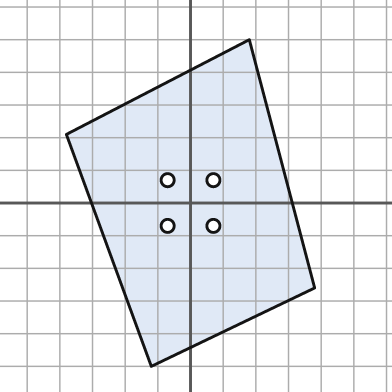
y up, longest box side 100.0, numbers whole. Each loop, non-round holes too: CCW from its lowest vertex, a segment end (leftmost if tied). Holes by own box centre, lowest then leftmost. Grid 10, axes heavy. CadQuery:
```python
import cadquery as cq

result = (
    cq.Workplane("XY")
    .moveTo(-12.0, -50.0)
    .lineTo(38.0, -26.0)
    .lineTo(18.0, 50.0)
    .lineTo(-38.0, 21.0)
    .close()
    .moveTo(-7.0, -7.0)
    .circle(2.0)
    .moveTo(7.0, -7.0)
    .circle(2.0)
    .moveTo(-7.0, 7.0)
    .circle(2.0)
    .moveTo(7.0, 7.0)
    .circle(2.0)
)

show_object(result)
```